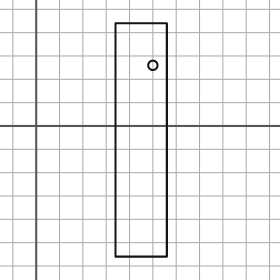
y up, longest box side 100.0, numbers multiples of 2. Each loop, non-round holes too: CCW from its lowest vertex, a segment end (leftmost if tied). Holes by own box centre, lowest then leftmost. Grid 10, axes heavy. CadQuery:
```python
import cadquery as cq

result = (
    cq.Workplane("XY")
    .moveTo(34.0, -56.0)
    .lineTo(56.0, -56.0)
    .lineTo(56.0, 44.0)
    .lineTo(34.0, 44.0)
    .close()
    .moveTo(50.0, 26.0)
    .circle(2.0)
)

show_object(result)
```